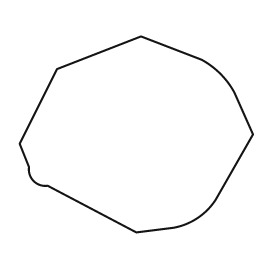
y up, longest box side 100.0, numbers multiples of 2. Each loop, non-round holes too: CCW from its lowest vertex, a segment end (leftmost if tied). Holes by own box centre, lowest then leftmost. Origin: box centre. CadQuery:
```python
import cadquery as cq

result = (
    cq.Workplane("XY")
    .moveTo(0.0, -42.0)
    .lineTo(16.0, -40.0)
    .threePointArc((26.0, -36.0), (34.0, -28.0))
    .lineTo(50.0, 0.0)
    .lineTo(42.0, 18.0)
    .threePointArc((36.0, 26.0), (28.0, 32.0))
    .lineTo(2.0, 42.0)
    .lineTo(-34.0, 28.0)
    .lineTo(-50.0, -4.0)
    .lineTo(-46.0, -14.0)
    .threePointArc((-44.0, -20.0), (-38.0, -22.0))
    .close()
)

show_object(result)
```